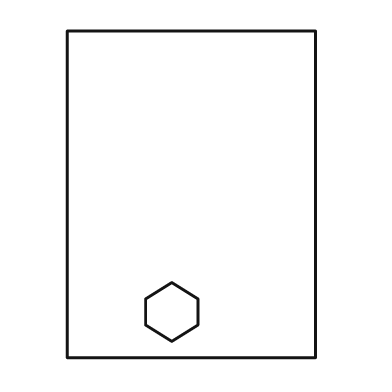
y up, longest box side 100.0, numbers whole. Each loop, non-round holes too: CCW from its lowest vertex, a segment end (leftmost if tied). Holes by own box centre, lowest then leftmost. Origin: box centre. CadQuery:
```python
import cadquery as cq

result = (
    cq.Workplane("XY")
    .moveTo(-38.0, -50.0)
    .lineTo(38.0, -50.0)
    .lineTo(38.0, 50.0)
    .lineTo(-38.0, 50.0)
    .close()
    .moveTo(-6.0, -45.0)
    .lineTo(2.0, -40.0)
    .lineTo(2.0, -32.0)
    .lineTo(-6.0, -27.0)
    .lineTo(-14.0, -32.0)
    .lineTo(-14.0, -40.0)
    .close()
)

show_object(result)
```